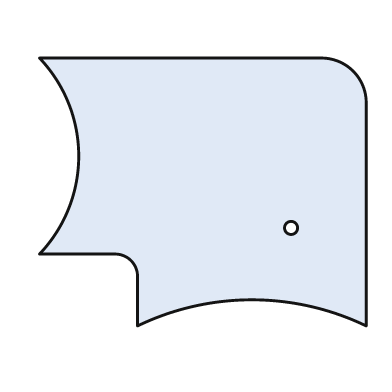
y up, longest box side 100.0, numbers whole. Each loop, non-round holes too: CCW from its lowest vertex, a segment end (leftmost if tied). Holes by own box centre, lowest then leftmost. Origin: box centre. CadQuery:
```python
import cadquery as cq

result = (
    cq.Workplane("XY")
    .moveTo(-20.0, -41.0)
    .threePointArc((15.0, -33.0), (50.0, -41.0))
    .lineTo(50.0, 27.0)
    .threePointArc((46.0, 37.0), (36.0, 41.0))
    .lineTo(-50.0, 41.0)
    .threePointArc((-38.0, 11.0), (-50.0, -19.0))
    .lineTo(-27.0, -19.0)
    .threePointArc((-22.0, -21.0), (-20.0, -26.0))
    .close()
    .moveTo(27.0, -11.0)
    .circle(2.0)
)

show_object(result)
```